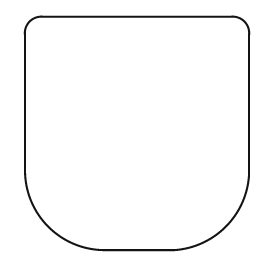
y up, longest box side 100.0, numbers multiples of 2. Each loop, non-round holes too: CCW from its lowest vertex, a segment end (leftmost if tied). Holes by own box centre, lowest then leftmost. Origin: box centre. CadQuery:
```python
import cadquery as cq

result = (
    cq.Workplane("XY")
    .moveTo(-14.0, -50.0)
    .lineTo(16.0, -50.0)
    .threePointArc((38.0, -40.0), (48.0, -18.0))
    .lineTo(48.0, 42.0)
    .threePointArc((46.0, 48.0), (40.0, 50.0))
    .lineTo(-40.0, 50.0)
    .threePointArc((-46.0, 48.0), (-48.0, 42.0))
    .lineTo(-48.0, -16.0)
    .threePointArc((-38.0, -40.0), (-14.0, -50.0))
    .close()
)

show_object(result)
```